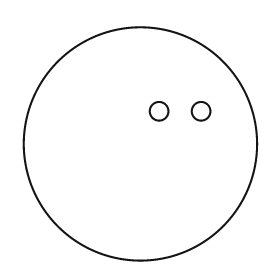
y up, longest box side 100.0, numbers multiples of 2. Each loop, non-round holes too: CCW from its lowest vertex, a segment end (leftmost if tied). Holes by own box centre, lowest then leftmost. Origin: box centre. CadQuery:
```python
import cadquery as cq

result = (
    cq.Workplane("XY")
    .moveTo(0.0, 0.0)
    .circle(50.0)
    .moveTo(8.0, 14.0)
    .circle(4.0)
    .moveTo(26.0, 14.0)
    .circle(4.0)
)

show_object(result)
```